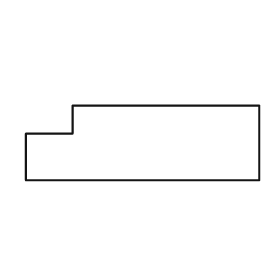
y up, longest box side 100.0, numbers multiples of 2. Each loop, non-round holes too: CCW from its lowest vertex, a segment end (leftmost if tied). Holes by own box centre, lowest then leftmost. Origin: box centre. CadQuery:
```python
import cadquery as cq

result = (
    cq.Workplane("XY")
    .moveTo(-50.0, -16.0)
    .lineTo(50.0, -16.0)
    .lineTo(50.0, 16.0)
    .lineTo(-30.0, 16.0)
    .lineTo(-30.0, 4.0)
    .lineTo(-50.0, 4.0)
    .close()
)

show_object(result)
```